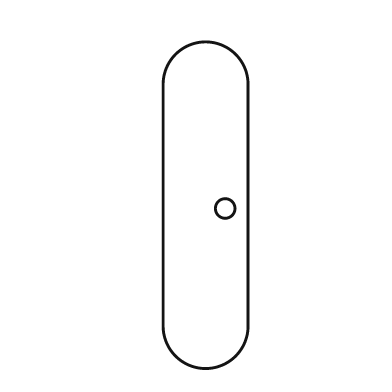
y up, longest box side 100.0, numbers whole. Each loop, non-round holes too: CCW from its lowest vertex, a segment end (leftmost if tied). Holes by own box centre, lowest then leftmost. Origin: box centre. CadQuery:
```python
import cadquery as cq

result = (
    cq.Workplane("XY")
    .moveTo(-13.0, -37.0)
    .threePointArc((0.0, -50.0), (13.0, -37.0))
    .lineTo(13.0, 37.0)
    .threePointArc((0.0, 50.0), (-13.0, 37.0))
    .close()
    .moveTo(6.0, -1.0)
    .circle(3.0)
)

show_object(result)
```